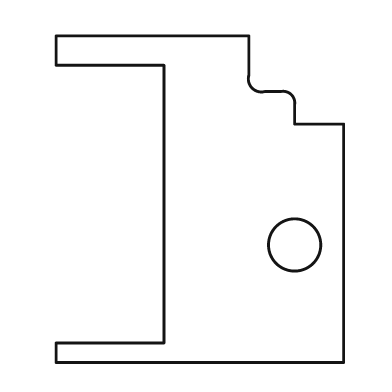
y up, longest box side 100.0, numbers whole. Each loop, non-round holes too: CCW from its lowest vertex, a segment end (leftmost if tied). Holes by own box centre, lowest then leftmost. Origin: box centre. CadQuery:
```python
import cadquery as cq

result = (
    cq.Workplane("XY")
    .moveTo(-44.0, -50.0)
    .lineTo(44.0, -50.0)
    .lineTo(44.0, 23.0)
    .lineTo(29.0, 23.0)
    .lineTo(29.0, 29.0)
    .threePointArc((28.0, 32.0), (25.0, 33.0))
    .lineTo(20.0, 33.0)
    .threePointArc((16.0, 34.0), (15.0, 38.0))
    .lineTo(15.0, 50.0)
    .lineTo(-44.0, 50.0)
    .lineTo(-44.0, 41.0)
    .lineTo(-11.0, 41.0)
    .lineTo(-11.0, -44.0)
    .lineTo(-44.0, -44.0)
    .close()
    .moveTo(29.0, -14.0)
    .circle(8.0)
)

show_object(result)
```